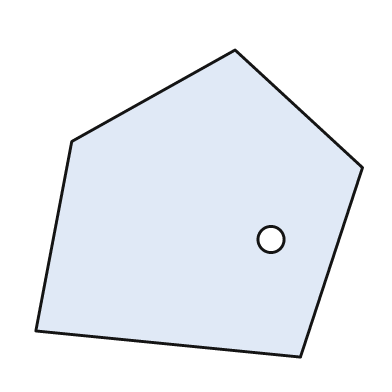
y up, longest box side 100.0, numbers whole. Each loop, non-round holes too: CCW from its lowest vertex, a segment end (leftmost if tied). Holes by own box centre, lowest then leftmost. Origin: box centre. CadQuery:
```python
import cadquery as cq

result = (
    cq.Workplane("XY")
    .moveTo(31.0, -47.0)
    .lineTo(50.0, 11.0)
    .lineTo(11.0, 47.0)
    .lineTo(-39.0, 19.0)
    .lineTo(-50.0, -39.0)
    .close()
    .moveTo(22.0, -11.0)
    .circle(4.0)
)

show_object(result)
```